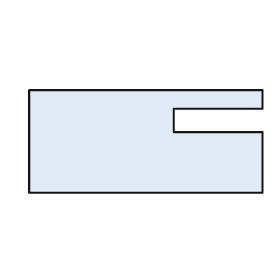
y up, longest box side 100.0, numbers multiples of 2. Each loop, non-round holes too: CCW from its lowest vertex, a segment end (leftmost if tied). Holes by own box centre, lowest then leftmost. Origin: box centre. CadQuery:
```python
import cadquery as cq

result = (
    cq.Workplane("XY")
    .moveTo(-50.0, -22.0)
    .lineTo(50.0, -22.0)
    .lineTo(50.0, 4.0)
    .lineTo(12.0, 4.0)
    .lineTo(12.0, 14.0)
    .lineTo(50.0, 14.0)
    .lineTo(50.0, 22.0)
    .lineTo(-50.0, 22.0)
    .close()
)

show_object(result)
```